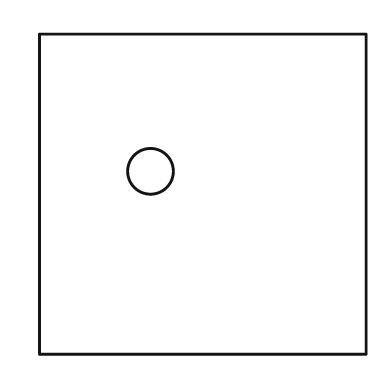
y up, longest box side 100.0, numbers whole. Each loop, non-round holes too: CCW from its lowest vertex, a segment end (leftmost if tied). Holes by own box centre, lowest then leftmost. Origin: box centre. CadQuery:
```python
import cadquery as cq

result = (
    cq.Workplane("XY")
    .moveTo(-50.0, -49.0)
    .lineTo(50.0, -49.0)
    .lineTo(50.0, 49.0)
    .lineTo(-50.0, 49.0)
    .close()
    .moveTo(-16.0, 7.0)
    .circle(7.0)
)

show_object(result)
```